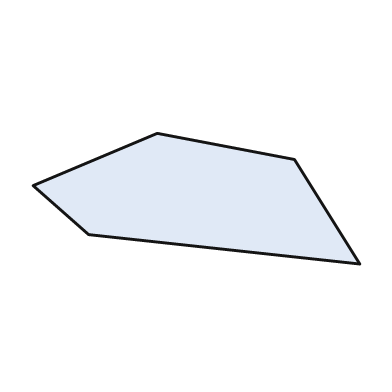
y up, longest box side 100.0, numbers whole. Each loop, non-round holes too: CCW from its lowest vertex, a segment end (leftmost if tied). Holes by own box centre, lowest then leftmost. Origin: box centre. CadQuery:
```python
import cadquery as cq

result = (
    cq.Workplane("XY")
    .moveTo(50.0, -20.0)
    .lineTo(30.0, 12.0)
    .lineTo(-12.0, 20.0)
    .lineTo(-50.0, 4.0)
    .lineTo(-33.0, -11.0)
    .close()
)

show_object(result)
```